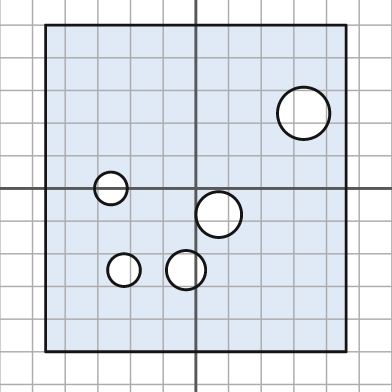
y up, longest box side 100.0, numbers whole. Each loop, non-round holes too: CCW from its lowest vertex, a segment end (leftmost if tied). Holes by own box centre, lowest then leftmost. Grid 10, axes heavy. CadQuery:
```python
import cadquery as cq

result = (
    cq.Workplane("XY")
    .moveTo(-46.0, -50.0)
    .lineTo(46.0, -50.0)
    .lineTo(46.0, 50.0)
    .lineTo(-46.0, 50.0)
    .close()
    .moveTo(-22.0, -25.0)
    .circle(5.0)
    .moveTo(-3.0, -25.0)
    .circle(6.0)
    .moveTo(7.0, -8.0)
    .circle(7.0)
    .moveTo(-26.0, 0.0)
    .circle(5.0)
    .moveTo(33.0, 23.0)
    .circle(8.0)
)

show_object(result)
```